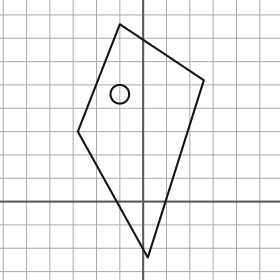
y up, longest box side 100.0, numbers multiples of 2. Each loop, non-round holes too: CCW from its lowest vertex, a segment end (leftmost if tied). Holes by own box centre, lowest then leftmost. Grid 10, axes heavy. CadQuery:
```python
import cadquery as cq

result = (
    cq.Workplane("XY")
    .moveTo(2.0, -24.0)
    .lineTo(26.0, 52.0)
    .lineTo(-10.0, 76.0)
    .lineTo(-28.0, 30.0)
    .close()
    .moveTo(-10.0, 46.0)
    .circle(4.0)
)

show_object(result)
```